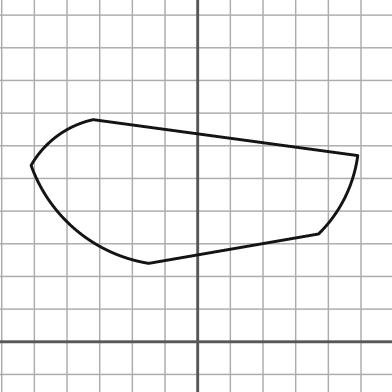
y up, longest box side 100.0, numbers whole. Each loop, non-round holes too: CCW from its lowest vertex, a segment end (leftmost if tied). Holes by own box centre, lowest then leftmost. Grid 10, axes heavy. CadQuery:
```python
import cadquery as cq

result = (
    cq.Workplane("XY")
    .moveTo(-15.0, 24.0)
    .lineTo(37.0, 33.0)
    .threePointArc((45.0, 44.0), (49.0, 57.0))
    .lineTo(-32.0, 68.0)
    .threePointArc((-43.0, 63.0), (-51.0, 54.0))
    .threePointArc((-37.0, 34.0), (-15.0, 24.0))
    .close()
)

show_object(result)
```